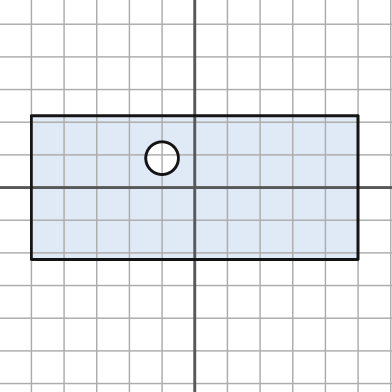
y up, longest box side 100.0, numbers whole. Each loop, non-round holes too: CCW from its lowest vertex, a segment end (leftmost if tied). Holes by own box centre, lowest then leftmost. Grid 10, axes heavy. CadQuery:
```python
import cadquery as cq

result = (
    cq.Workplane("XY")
    .moveTo(-50.0, -22.0)
    .lineTo(50.0, -22.0)
    .lineTo(50.0, 22.0)
    .lineTo(-50.0, 22.0)
    .close()
    .moveTo(-10.0, 9.0)
    .circle(5.0)
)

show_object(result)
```